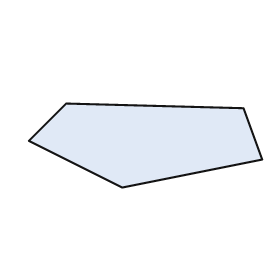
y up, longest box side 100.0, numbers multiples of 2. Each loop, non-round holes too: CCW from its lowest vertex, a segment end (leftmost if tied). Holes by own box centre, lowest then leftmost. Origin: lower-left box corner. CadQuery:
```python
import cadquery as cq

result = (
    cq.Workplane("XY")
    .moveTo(40.0, 0.0)
    .lineTo(100.0, 12.0)
    .lineTo(92.0, 34.0)
    .lineTo(16.0, 36.0)
    .lineTo(0.0, 20.0)
    .close()
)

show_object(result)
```